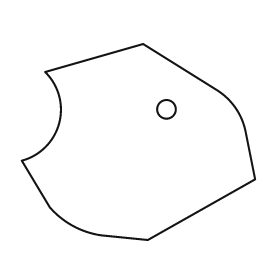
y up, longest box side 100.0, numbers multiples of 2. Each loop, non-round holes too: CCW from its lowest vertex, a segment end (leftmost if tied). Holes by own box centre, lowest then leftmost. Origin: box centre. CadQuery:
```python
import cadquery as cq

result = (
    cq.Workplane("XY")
    .moveTo(4.0, -42.0)
    .lineTo(50.0, -16.0)
    .lineTo(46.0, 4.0)
    .threePointArc((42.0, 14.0), (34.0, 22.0))
    .lineTo(2.0, 42.0)
    .lineTo(-40.0, 30.0)
    .threePointArc((-34.0, 8.0), (-50.0, -8.0))
    .lineTo(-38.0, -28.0)
    .threePointArc((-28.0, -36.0), (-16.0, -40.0))
    .close()
    .moveTo(12.0, 14.0)
    .circle(4.0)
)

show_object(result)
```